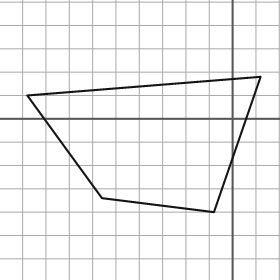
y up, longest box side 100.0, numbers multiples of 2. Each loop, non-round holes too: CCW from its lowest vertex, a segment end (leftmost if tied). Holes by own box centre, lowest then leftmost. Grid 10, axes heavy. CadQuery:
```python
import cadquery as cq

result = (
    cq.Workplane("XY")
    .moveTo(-8.0, -40.0)
    .lineTo(12.0, 18.0)
    .lineTo(-88.0, 10.0)
    .lineTo(-56.0, -34.0)
    .close()
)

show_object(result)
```